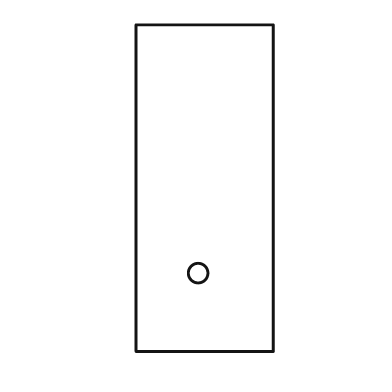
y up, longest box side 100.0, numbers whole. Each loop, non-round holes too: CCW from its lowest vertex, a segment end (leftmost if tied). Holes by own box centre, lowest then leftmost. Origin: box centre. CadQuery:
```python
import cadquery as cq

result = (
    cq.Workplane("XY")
    .moveTo(-21.0, -50.0)
    .lineTo(21.0, -50.0)
    .lineTo(21.0, 50.0)
    .lineTo(-21.0, 50.0)
    .close()
    .moveTo(-2.0, -26.0)
    .circle(3.0)
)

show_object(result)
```